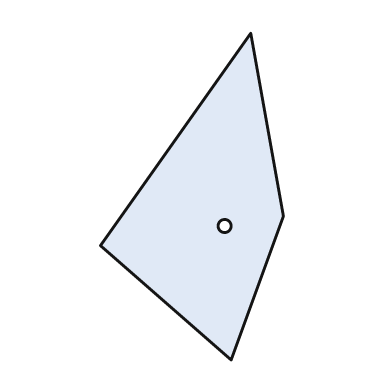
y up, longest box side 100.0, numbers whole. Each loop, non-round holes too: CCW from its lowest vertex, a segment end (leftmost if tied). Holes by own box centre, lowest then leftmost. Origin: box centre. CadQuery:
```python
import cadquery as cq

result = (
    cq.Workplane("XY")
    .moveTo(12.0, -50.0)
    .lineTo(28.0, -6.0)
    .lineTo(18.0, 50.0)
    .lineTo(-28.0, -15.0)
    .close()
    .moveTo(10.0, -9.0)
    .circle(2.0)
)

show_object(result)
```